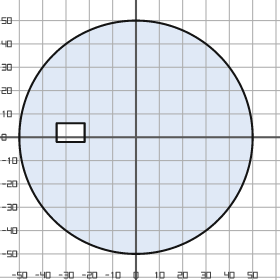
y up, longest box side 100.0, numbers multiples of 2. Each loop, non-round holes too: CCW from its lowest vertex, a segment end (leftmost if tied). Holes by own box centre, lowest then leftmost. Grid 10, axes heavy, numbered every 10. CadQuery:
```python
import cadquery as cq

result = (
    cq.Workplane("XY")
    .moveTo(0.0, 0.0)
    .circle(50.0)
    .moveTo(-34.0, -2.0)
    .lineTo(-22.0, -2.0)
    .lineTo(-22.0, 6.0)
    .lineTo(-34.0, 6.0)
    .close()
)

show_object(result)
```